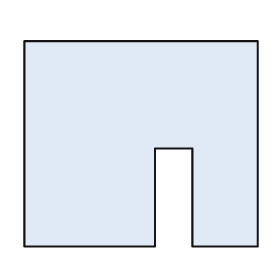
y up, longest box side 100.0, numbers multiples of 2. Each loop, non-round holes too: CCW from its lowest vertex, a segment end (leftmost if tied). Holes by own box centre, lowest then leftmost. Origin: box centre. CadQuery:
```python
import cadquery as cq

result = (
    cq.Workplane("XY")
    .moveTo(-50.0, -44.0)
    .lineTo(6.0, -44.0)
    .lineTo(6.0, -2.0)
    .lineTo(22.0, -2.0)
    .lineTo(22.0, -44.0)
    .lineTo(50.0, -44.0)
    .lineTo(50.0, 44.0)
    .lineTo(-50.0, 44.0)
    .close()
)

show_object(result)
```